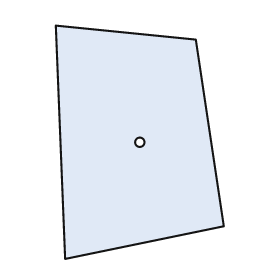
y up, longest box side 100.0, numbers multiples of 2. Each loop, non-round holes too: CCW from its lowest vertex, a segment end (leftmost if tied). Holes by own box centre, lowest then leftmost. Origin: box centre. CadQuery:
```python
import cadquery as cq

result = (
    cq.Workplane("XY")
    .moveTo(-32.0, -50.0)
    .lineTo(36.0, -36.0)
    .lineTo(24.0, 44.0)
    .lineTo(-36.0, 50.0)
    .close()
    .moveTo(0.0, 0.0)
    .circle(2.0)
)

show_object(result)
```